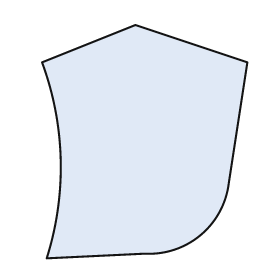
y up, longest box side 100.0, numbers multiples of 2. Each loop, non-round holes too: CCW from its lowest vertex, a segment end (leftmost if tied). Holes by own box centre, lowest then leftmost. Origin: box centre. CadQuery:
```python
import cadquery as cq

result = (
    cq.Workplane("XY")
    .moveTo(-42.0, -50.0)
    .lineTo(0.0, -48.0)
    .threePointArc((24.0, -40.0), (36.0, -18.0))
    .lineTo(44.0, 34.0)
    .lineTo(-4.0, 50.0)
    .lineTo(-44.0, 34.0)
    .threePointArc((-36.0, -8.0), (-42.0, -50.0))
    .close()
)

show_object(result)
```